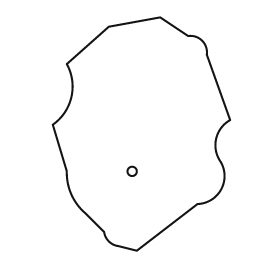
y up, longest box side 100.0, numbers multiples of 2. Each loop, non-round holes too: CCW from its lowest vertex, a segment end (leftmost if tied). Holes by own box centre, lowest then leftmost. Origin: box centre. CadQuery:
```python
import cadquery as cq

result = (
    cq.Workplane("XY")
    .moveTo(-2.0, -50.0)
    .lineTo(24.0, -30.0)
    .threePointArc((34.0, -24.0), (34.0, -12.0))
    .threePointArc((32.0, -2.0), (38.0, 6.0))
    .lineTo(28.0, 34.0)
    .threePointArc((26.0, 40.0), (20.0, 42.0))
    .lineTo(8.0, 50.0)
    .lineTo(-14.0, 46.0)
    .lineTo(-32.0, 30.0)
    .threePointArc((-30.0, 16.0), (-38.0, 4.0))
    .lineTo(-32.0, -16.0)
    .threePointArc((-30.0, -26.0), (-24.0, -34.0))
    .lineTo(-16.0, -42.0)
    .threePointArc((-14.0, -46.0), (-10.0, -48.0))
    .close()
    .moveTo(-4.0, -16.0)
    .circle(2.0)
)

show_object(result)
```